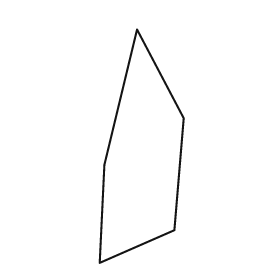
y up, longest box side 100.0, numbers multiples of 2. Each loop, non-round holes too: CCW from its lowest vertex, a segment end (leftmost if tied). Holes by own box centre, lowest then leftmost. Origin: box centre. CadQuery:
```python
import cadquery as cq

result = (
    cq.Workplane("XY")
    .moveTo(-18.0, -50.0)
    .lineTo(14.0, -36.0)
    .lineTo(18.0, 12.0)
    .lineTo(-2.0, 50.0)
    .lineTo(-16.0, -8.0)
    .close()
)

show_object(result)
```